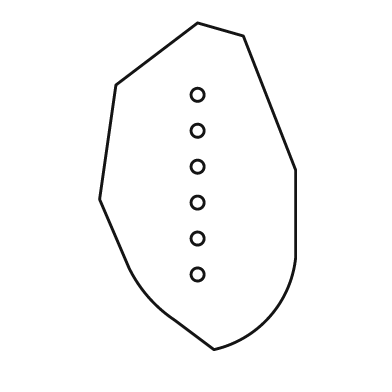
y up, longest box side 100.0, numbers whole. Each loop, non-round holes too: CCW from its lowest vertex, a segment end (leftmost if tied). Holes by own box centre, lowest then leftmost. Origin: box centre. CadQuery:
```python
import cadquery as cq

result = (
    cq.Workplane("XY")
    .moveTo(5.0, -50.0)
    .threePointArc((22.0, -40.0), (30.0, -22.0))
    .lineTo(30.0, 5.0)
    .lineTo(14.0, 46.0)
    .lineTo(0.0, 50.0)
    .lineTo(-25.0, 31.0)
    .lineTo(-30.0, -4.0)
    .lineTo(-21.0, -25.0)
    .threePointArc((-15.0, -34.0), (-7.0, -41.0))
    .close()
    .moveTo(0.0, -27.0)
    .circle(2.0)
    .moveTo(0.0, -16.0)
    .circle(2.0)
    .moveTo(0.0, -5.0)
    .circle(2.0)
    .moveTo(0.0, 6.0)
    .circle(2.0)
    .moveTo(0.0, 17.0)
    .circle(2.0)
    .moveTo(0.0, 28.0)
    .circle(2.0)
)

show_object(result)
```